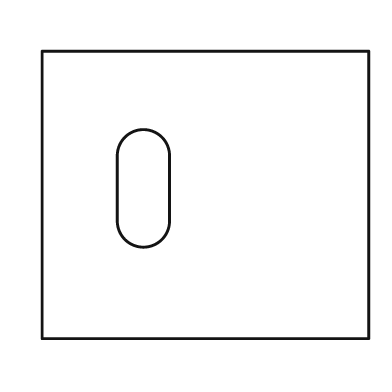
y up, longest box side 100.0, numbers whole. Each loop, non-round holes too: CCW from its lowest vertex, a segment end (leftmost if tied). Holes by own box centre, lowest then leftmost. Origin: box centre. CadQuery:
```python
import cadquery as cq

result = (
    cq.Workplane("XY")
    .moveTo(-50.0, -44.0)
    .lineTo(50.0, -44.0)
    .lineTo(50.0, 44.0)
    .lineTo(-50.0, 44.0)
    .close()
    .moveTo(-27.0, -8.0)
    .threePointArc((-19.0, -16.0), (-11.0, -8.0))
    .lineTo(-11.0, 12.0)
    .threePointArc((-19.0, 20.0), (-27.0, 12.0))
    .close()
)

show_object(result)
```